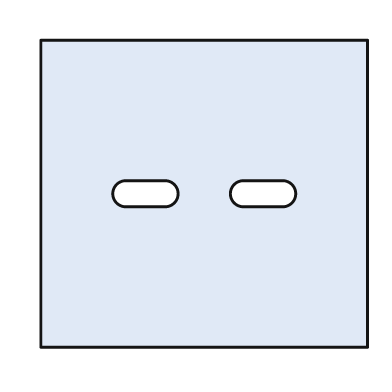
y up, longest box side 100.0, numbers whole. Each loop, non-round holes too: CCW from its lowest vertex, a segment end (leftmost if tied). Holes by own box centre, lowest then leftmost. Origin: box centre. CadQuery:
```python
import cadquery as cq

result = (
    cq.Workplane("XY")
    .moveTo(-50.0, -47.0)
    .lineTo(50.0, -47.0)
    .lineTo(50.0, 47.0)
    .lineTo(-50.0, 47.0)
    .close()
    .moveTo(-24.0, -4.0)
    .lineTo(-12.0, -4.0)
    .threePointArc((-8.0, 0.0), (-12.0, 4.0))
    .lineTo(-24.0, 4.0)
    .threePointArc((-28.0, 0.0), (-24.0, -4.0))
    .close()
    .moveTo(12.0, -4.0)
    .lineTo(24.0, -4.0)
    .threePointArc((28.0, 0.0), (24.0, 4.0))
    .lineTo(12.0, 4.0)
    .threePointArc((8.0, 0.0), (12.0, -4.0))
    .close()
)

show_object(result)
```